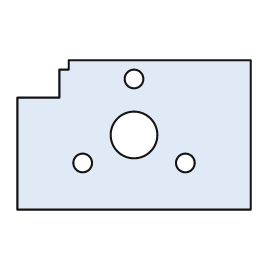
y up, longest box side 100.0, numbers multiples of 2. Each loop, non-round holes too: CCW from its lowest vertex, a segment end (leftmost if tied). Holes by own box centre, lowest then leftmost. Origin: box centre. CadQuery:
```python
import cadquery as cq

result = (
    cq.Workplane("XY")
    .moveTo(-50.0, -32.0)
    .lineTo(50.0, -32.0)
    .lineTo(50.0, 32.0)
    .lineTo(-28.0, 32.0)
    .lineTo(-28.0, 28.0)
    .lineTo(-32.0, 28.0)
    .lineTo(-32.0, 16.0)
    .lineTo(-50.0, 16.0)
    .close()
    .moveTo(-22.0, -12.0)
    .circle(4.0)
    .moveTo(22.0, -12.0)
    .circle(4.0)
    .moveTo(0.0, 0.0)
    .circle(10.0)
    .moveTo(0.0, 24.0)
    .circle(4.0)
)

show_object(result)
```